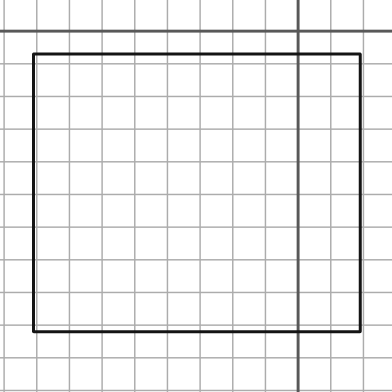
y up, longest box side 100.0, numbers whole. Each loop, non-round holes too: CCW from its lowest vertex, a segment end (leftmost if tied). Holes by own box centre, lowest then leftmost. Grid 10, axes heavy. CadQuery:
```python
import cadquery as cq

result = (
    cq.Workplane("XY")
    .moveTo(-81.0, -92.0)
    .lineTo(19.0, -92.0)
    .lineTo(19.0, -7.0)
    .lineTo(-81.0, -7.0)
    .close()
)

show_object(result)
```